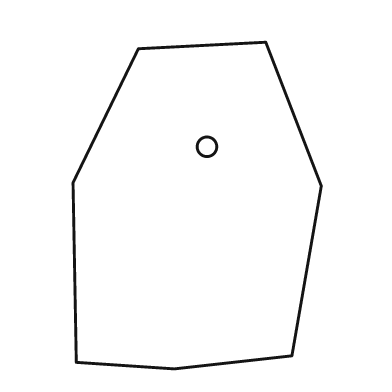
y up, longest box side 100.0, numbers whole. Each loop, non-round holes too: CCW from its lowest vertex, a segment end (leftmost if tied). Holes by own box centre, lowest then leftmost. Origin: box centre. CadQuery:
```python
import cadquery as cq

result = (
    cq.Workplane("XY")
    .moveTo(-7.0, -50.0)
    .lineTo(29.0, -46.0)
    .lineTo(38.0, 6.0)
    .lineTo(21.0, 50.0)
    .lineTo(-18.0, 48.0)
    .lineTo(-38.0, 7.0)
    .lineTo(-37.0, -48.0)
    .close()
    .moveTo(3.0, 18.0)
    .circle(3.0)
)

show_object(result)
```